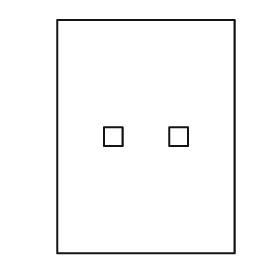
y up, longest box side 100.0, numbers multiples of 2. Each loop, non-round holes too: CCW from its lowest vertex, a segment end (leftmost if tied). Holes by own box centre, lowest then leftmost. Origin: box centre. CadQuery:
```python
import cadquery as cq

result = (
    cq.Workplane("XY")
    .moveTo(-38.0, -50.0)
    .lineTo(38.0, -50.0)
    .lineTo(38.0, 50.0)
    .lineTo(-38.0, 50.0)
    .close()
    .moveTo(-18.0, -4.0)
    .lineTo(-10.0, -4.0)
    .lineTo(-10.0, 4.0)
    .lineTo(-18.0, 4.0)
    .close()
    .moveTo(10.0, -4.0)
    .lineTo(18.0, -4.0)
    .lineTo(18.0, 4.0)
    .lineTo(10.0, 4.0)
    .close()
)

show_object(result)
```